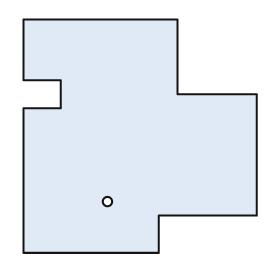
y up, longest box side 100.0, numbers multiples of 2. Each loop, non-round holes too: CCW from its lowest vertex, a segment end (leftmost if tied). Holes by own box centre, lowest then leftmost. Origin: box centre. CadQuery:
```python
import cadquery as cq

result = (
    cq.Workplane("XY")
    .moveTo(-50.0, -50.0)
    .lineTo(8.0, -50.0)
    .lineTo(8.0, -34.0)
    .lineTo(50.0, -34.0)
    .lineTo(50.0, 18.0)
    .lineTo(16.0, 18.0)
    .lineTo(16.0, 50.0)
    .lineTo(-50.0, 50.0)
    .lineTo(-50.0, 24.0)
    .lineTo(-34.0, 24.0)
    .lineTo(-34.0, 12.0)
    .lineTo(-50.0, 12.0)
    .close()
    .moveTo(-14.0, -28.0)
    .circle(2.0)
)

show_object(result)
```